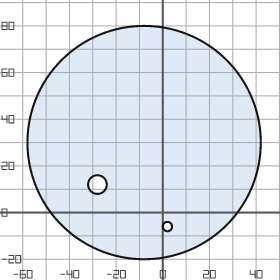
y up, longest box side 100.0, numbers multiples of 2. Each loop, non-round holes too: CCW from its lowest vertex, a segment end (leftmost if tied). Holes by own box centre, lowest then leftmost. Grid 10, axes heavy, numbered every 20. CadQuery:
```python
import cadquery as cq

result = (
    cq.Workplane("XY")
    .moveTo(-8.0, 30.0)
    .circle(50.0)
    .moveTo(2.0, -6.0)
    .circle(2.0)
    .moveTo(-28.0, 12.0)
    .circle(4.0)
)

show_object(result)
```